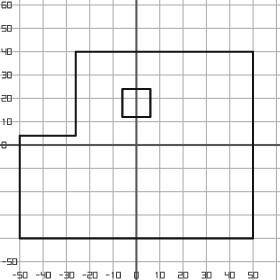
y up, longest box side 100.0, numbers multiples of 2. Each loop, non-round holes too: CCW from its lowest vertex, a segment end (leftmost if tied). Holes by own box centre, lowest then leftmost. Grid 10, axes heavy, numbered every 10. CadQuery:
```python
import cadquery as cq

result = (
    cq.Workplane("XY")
    .moveTo(-50.0, -40.0)
    .lineTo(50.0, -40.0)
    .lineTo(50.0, 40.0)
    .lineTo(-26.0, 40.0)
    .lineTo(-26.0, 4.0)
    .lineTo(-50.0, 4.0)
    .close()
    .moveTo(-6.0, 12.0)
    .lineTo(6.0, 12.0)
    .lineTo(6.0, 24.0)
    .lineTo(-6.0, 24.0)
    .close()
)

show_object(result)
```